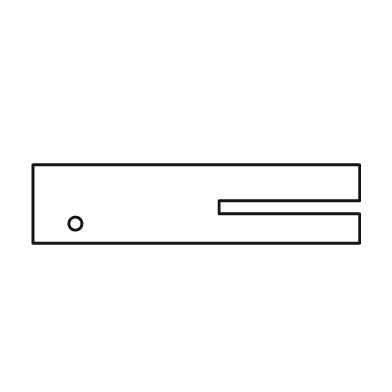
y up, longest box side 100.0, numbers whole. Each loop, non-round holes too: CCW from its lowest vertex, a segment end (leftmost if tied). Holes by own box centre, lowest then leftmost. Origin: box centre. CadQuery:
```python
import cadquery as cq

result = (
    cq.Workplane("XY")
    .moveTo(-50.0, -12.0)
    .lineTo(50.0, -12.0)
    .lineTo(50.0, -3.0)
    .lineTo(7.0, -3.0)
    .lineTo(7.0, 1.0)
    .lineTo(50.0, 1.0)
    .lineTo(50.0, 12.0)
    .lineTo(-50.0, 12.0)
    .close()
    .moveTo(-37.0, -6.0)
    .circle(2.0)
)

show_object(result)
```